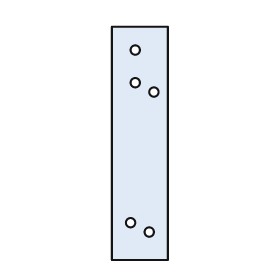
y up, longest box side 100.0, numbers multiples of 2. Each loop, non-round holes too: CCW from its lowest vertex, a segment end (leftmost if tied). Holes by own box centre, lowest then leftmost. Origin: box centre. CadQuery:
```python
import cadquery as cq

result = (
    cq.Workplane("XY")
    .moveTo(-12.0, -50.0)
    .lineTo(12.0, -50.0)
    .lineTo(12.0, 50.0)
    .lineTo(-12.0, 50.0)
    .close()
    .moveTo(4.0, -38.0)
    .circle(2.0)
    .moveTo(-4.0, -34.0)
    .circle(2.0)
    .moveTo(6.0, 22.0)
    .circle(2.0)
    .moveTo(-2.0, 26.0)
    .circle(2.0)
    .moveTo(-2.0, 40.0)
    .circle(2.0)
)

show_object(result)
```